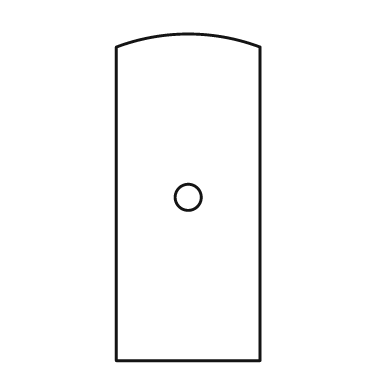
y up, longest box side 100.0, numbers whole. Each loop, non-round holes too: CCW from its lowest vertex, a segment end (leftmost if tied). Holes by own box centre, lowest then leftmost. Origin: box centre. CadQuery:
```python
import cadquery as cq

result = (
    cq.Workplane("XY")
    .moveTo(-22.0, -50.0)
    .lineTo(22.0, -50.0)
    .lineTo(22.0, 46.0)
    .threePointArc((0.0, 50.0), (-22.0, 46.0))
    .close()
    .moveTo(0.0, 0.0)
    .circle(4.0)
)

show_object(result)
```